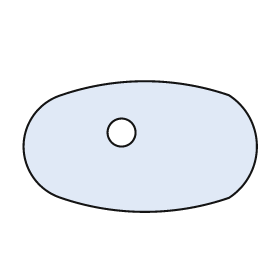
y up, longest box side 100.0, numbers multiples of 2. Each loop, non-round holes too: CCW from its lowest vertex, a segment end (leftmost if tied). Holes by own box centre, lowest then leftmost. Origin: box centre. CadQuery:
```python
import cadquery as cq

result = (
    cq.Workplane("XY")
    .moveTo(-34.0, -22.0)
    .threePointArc((2.0, -28.0), (38.0, -22.0))
    .threePointArc((50.0, 0.0), (38.0, 22.0))
    .threePointArc((2.0, 28.0), (-34.0, 22.0))
    .threePointArc((-50.0, 0.0), (-34.0, -22.0))
    .close()
    .moveTo(-8.0, 6.0)
    .circle(6.0)
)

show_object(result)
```